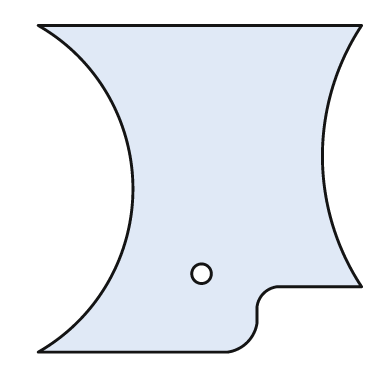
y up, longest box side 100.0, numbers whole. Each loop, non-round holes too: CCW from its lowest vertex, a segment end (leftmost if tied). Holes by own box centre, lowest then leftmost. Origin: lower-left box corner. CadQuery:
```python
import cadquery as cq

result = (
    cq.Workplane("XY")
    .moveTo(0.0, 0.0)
    .lineTo(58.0, 0.0)
    .threePointArc((64.0, 3.0), (67.0, 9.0))
    .lineTo(67.0, 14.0)
    .threePointArc((69.0, 18.0), (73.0, 20.0))
    .lineTo(99.0, 20.0)
    .threePointArc((87.0, 60.0), (99.0, 100.0))
    .lineTo(0.0, 100.0)
    .threePointArc((29.0, 50.0), (0.0, 0.0))
    .close()
    .moveTo(50.0, 24.0)
    .circle(3.0)
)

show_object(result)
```